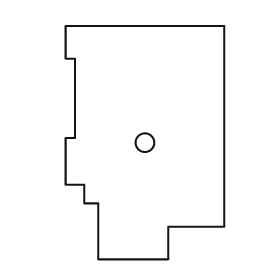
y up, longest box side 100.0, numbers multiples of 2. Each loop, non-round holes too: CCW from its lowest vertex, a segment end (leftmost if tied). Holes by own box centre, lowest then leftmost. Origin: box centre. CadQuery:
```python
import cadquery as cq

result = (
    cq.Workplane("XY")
    .moveTo(-20.0, -50.0)
    .lineTo(10.0, -50.0)
    .lineTo(10.0, -36.0)
    .lineTo(34.0, -36.0)
    .lineTo(34.0, 50.0)
    .lineTo(-34.0, 50.0)
    .lineTo(-34.0, 36.0)
    .lineTo(-30.0, 36.0)
    .lineTo(-30.0, 2.0)
    .lineTo(-34.0, 2.0)
    .lineTo(-34.0, -18.0)
    .lineTo(-26.0, -18.0)
    .lineTo(-26.0, -26.0)
    .lineTo(-20.0, -26.0)
    .close()
    .moveTo(0.0, 0.0)
    .circle(4.0)
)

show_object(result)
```